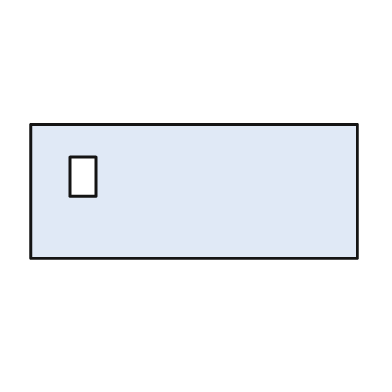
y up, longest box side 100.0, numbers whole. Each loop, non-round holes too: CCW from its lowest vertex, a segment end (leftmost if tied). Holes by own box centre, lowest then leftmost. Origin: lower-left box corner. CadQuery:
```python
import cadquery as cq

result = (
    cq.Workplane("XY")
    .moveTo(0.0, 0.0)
    .lineTo(100.0, 0.0)
    .lineTo(100.0, 41.0)
    .lineTo(0.0, 41.0)
    .close()
    .moveTo(12.0, 19.0)
    .lineTo(20.0, 19.0)
    .lineTo(20.0, 31.0)
    .lineTo(12.0, 31.0)
    .close()
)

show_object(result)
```